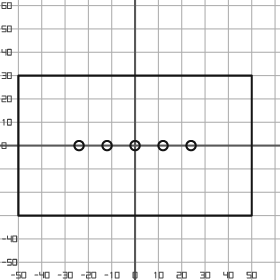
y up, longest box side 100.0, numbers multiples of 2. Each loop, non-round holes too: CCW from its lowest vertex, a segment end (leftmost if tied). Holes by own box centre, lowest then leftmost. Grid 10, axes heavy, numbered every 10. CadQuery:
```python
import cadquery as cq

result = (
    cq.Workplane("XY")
    .moveTo(-50.0, -30.0)
    .lineTo(50.0, -30.0)
    .lineTo(50.0, 30.0)
    .lineTo(-50.0, 30.0)
    .close()
    .moveTo(-24.0, 0.0)
    .circle(2.0)
    .moveTo(-12.0, 0.0)
    .circle(2.0)
    .moveTo(0.0, 0.0)
    .circle(2.0)
    .moveTo(12.0, 0.0)
    .circle(2.0)
    .moveTo(24.0, 0.0)
    .circle(2.0)
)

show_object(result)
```